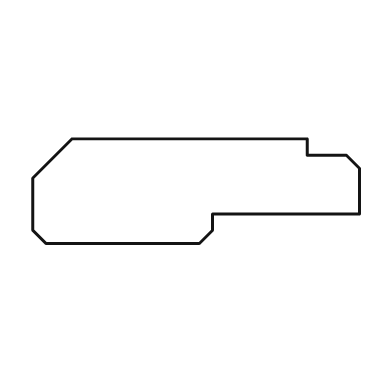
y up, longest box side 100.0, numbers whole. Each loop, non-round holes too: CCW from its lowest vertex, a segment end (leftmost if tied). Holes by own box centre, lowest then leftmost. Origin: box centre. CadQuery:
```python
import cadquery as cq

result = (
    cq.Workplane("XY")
    .moveTo(-46.0, -16.0)
    .lineTo(1.0, -16.0)
    .lineTo(5.0, -12.0)
    .lineTo(5.0, -7.0)
    .lineTo(50.0, -7.0)
    .lineTo(50.0, 7.0)
    .lineTo(46.0, 11.0)
    .lineTo(34.0, 11.0)
    .lineTo(34.0, 16.0)
    .lineTo(-38.0, 16.0)
    .lineTo(-50.0, 4.0)
    .lineTo(-50.0, -12.0)
    .close()
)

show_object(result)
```